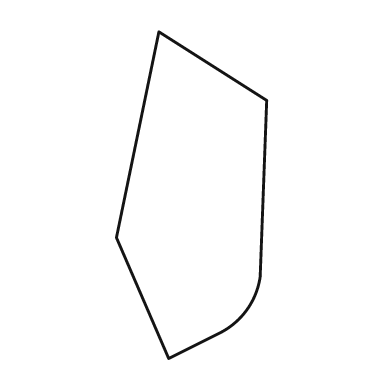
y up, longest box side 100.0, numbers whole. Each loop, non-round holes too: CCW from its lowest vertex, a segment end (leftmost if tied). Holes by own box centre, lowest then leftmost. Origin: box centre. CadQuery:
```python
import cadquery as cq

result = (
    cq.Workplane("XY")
    .moveTo(-7.0, -50.0)
    .lineTo(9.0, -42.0)
    .threePointArc((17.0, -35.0), (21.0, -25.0))
    .lineTo(23.0, 29.0)
    .lineTo(-10.0, 50.0)
    .lineTo(-23.0, -13.0)
    .close()
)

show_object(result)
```